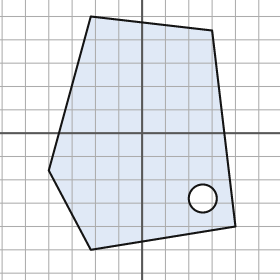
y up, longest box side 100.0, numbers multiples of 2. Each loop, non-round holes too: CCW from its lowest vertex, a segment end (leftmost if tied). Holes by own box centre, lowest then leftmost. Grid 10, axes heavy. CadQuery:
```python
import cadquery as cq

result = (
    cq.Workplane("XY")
    .moveTo(-22.0, -50.0)
    .lineTo(40.0, -40.0)
    .lineTo(30.0, 44.0)
    .lineTo(-22.0, 50.0)
    .lineTo(-40.0, -16.0)
    .close()
    .moveTo(26.0, -28.0)
    .circle(6.0)
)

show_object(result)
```